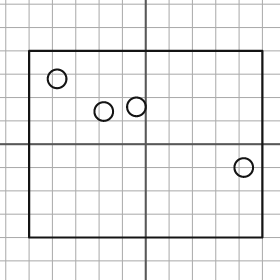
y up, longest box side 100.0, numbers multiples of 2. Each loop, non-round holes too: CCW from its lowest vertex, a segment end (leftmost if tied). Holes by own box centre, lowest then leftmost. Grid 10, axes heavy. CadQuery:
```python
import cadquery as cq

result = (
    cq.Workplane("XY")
    .moveTo(-50.0, -40.0)
    .lineTo(50.0, -40.0)
    .lineTo(50.0, 40.0)
    .lineTo(-50.0, 40.0)
    .close()
    .moveTo(42.0, -10.0)
    .circle(4.0)
    .moveTo(-18.0, 14.0)
    .circle(4.0)
    .moveTo(-4.0, 16.0)
    .circle(4.0)
    .moveTo(-38.0, 28.0)
    .circle(4.0)
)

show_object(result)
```